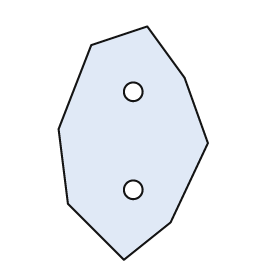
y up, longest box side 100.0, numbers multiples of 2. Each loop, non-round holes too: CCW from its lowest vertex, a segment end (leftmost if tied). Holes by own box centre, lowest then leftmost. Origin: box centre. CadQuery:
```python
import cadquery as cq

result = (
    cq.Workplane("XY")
    .moveTo(-4.0, -50.0)
    .lineTo(16.0, -34.0)
    .lineTo(32.0, 0.0)
    .lineTo(22.0, 28.0)
    .lineTo(6.0, 50.0)
    .lineTo(-18.0, 42.0)
    .lineTo(-32.0, 6.0)
    .lineTo(-28.0, -26.0)
    .close()
    .moveTo(0.0, -20.0)
    .circle(4.0)
    .moveTo(0.0, 22.0)
    .circle(4.0)
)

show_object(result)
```